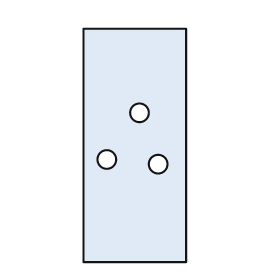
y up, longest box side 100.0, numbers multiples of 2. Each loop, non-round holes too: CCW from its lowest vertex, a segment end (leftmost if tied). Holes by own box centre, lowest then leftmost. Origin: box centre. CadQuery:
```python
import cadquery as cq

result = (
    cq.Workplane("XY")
    .moveTo(-22.0, -50.0)
    .lineTo(22.0, -50.0)
    .lineTo(22.0, 50.0)
    .lineTo(-22.0, 50.0)
    .close()
    .moveTo(10.0, -8.0)
    .circle(4.0)
    .moveTo(-12.0, -6.0)
    .circle(4.0)
    .moveTo(2.0, 14.0)
    .circle(4.0)
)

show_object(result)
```